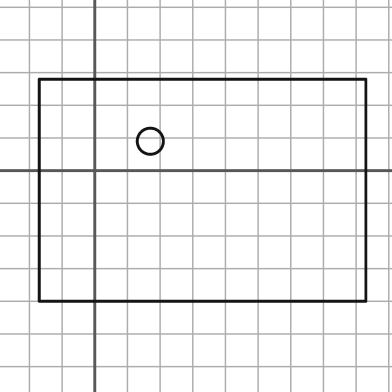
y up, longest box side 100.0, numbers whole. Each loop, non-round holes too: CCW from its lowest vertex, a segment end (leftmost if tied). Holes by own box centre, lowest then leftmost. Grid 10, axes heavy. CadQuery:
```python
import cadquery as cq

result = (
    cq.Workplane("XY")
    .moveTo(-17.0, -40.0)
    .lineTo(83.0, -40.0)
    .lineTo(83.0, 28.0)
    .lineTo(-17.0, 28.0)
    .close()
    .moveTo(17.0, 9.0)
    .circle(4.0)
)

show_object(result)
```